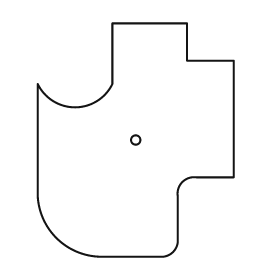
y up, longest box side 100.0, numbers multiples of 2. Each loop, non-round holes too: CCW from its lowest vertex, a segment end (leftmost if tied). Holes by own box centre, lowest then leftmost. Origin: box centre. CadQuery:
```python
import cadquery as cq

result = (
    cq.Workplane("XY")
    .moveTo(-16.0, -50.0)
    .lineTo(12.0, -50.0)
    .threePointArc((16.0, -48.0), (18.0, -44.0))
    .lineTo(18.0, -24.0)
    .threePointArc((20.0, -18.0), (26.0, -16.0))
    .lineTo(42.0, -16.0)
    .lineTo(42.0, 34.0)
    .lineTo(22.0, 34.0)
    .lineTo(22.0, 50.0)
    .lineTo(-10.0, 50.0)
    .lineTo(-10.0, 24.0)
    .threePointArc((-26.0, 14.0), (-42.0, 24.0))
    .lineTo(-42.0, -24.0)
    .threePointArc((-34.0, -42.0), (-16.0, -50.0))
    .close()
    .moveTo(0.0, 0.0)
    .circle(2.0)
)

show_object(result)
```